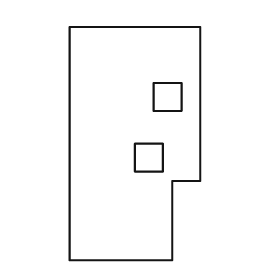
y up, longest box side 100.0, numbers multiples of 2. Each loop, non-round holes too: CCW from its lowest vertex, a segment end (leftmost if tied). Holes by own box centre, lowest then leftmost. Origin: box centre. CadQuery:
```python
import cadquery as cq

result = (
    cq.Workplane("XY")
    .moveTo(-28.0, -50.0)
    .lineTo(16.0, -50.0)
    .lineTo(16.0, -16.0)
    .lineTo(28.0, -16.0)
    .lineTo(28.0, 50.0)
    .lineTo(-28.0, 50.0)
    .close()
    .moveTo(0.0, -12.0)
    .lineTo(12.0, -12.0)
    .lineTo(12.0, 0.0)
    .lineTo(0.0, 0.0)
    .close()
    .moveTo(8.0, 14.0)
    .lineTo(20.0, 14.0)
    .lineTo(20.0, 26.0)
    .lineTo(8.0, 26.0)
    .close()
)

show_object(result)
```